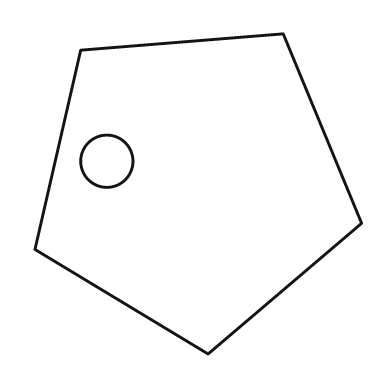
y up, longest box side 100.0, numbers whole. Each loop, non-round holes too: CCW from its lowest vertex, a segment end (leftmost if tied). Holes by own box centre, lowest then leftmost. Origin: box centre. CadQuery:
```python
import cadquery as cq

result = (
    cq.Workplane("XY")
    .moveTo(3.0, -49.0)
    .lineTo(50.0, -9.0)
    .lineTo(26.0, 49.0)
    .lineTo(-36.0, 44.0)
    .lineTo(-50.0, -17.0)
    .close()
    .moveTo(-28.0, 10.0)
    .circle(8.0)
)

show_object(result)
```